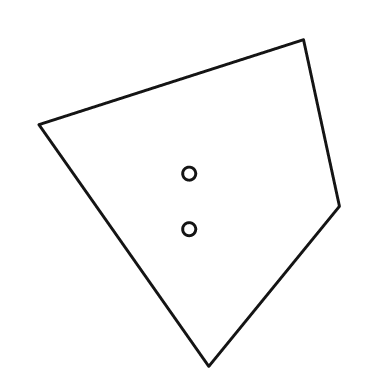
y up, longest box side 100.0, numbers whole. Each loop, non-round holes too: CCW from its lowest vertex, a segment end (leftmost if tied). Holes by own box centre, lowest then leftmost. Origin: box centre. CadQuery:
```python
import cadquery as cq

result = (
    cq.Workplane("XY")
    .moveTo(6.0, -50.0)
    .lineTo(46.0, -1.0)
    .lineTo(35.0, 50.0)
    .lineTo(-46.0, 24.0)
    .close()
    .moveTo(0.0, -8.0)
    .circle(2.0)
    .moveTo(0.0, 9.0)
    .circle(2.0)
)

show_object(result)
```